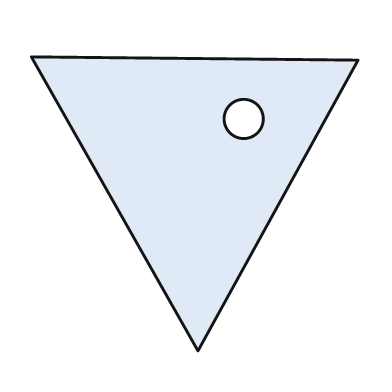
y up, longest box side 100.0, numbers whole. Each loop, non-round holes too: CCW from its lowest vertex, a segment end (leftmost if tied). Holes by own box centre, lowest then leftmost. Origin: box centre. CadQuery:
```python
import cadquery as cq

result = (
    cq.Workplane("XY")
    .moveTo(1.0, -45.0)
    .lineTo(50.0, 44.0)
    .lineTo(-50.0, 45.0)
    .close()
    .moveTo(15.0, 26.0)
    .circle(6.0)
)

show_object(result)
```